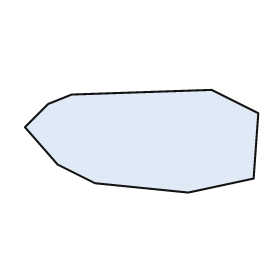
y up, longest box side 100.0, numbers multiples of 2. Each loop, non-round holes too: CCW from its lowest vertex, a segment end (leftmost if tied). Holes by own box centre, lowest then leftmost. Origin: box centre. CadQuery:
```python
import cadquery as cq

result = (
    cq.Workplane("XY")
    .moveTo(20.0, -22.0)
    .lineTo(48.0, -16.0)
    .lineTo(50.0, 12.0)
    .lineTo(30.0, 22.0)
    .lineTo(-30.0, 20.0)
    .lineTo(-40.0, 16.0)
    .lineTo(-50.0, 6.0)
    .lineTo(-36.0, -10.0)
    .lineTo(-20.0, -18.0)
    .close()
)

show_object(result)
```